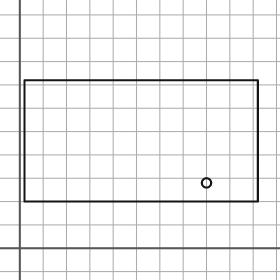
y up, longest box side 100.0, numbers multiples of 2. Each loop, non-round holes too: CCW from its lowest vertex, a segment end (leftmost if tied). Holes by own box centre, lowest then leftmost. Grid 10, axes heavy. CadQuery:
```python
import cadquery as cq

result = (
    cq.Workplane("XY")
    .moveTo(2.0, 20.0)
    .lineTo(102.0, 20.0)
    .lineTo(102.0, 72.0)
    .lineTo(2.0, 72.0)
    .close()
    .moveTo(80.0, 28.0)
    .circle(2.0)
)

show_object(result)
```